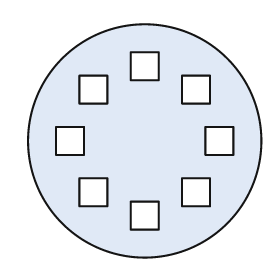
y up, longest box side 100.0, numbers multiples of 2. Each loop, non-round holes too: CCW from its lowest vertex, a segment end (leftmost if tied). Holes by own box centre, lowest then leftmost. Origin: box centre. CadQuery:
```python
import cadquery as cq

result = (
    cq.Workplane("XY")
    .moveTo(0.0, 0.0)
    .circle(50.0)
    .moveTo(-6.0, -38.0)
    .lineTo(6.0, -38.0)
    .lineTo(6.0, -26.0)
    .lineTo(-6.0, -26.0)
    .close()
    .moveTo(-28.0, -28.0)
    .lineTo(-16.0, -28.0)
    .lineTo(-16.0, -16.0)
    .lineTo(-28.0, -16.0)
    .close()
    .moveTo(16.0, -28.0)
    .lineTo(28.0, -28.0)
    .lineTo(28.0, -16.0)
    .lineTo(16.0, -16.0)
    .close()
    .moveTo(-38.0, -6.0)
    .lineTo(-26.0, -6.0)
    .lineTo(-26.0, 6.0)
    .lineTo(-38.0, 6.0)
    .close()
    .moveTo(26.0, -6.0)
    .lineTo(38.0, -6.0)
    .lineTo(38.0, 6.0)
    .lineTo(26.0, 6.0)
    .close()
    .moveTo(-28.0, 16.0)
    .lineTo(-16.0, 16.0)
    .lineTo(-16.0, 28.0)
    .lineTo(-28.0, 28.0)
    .close()
    .moveTo(16.0, 16.0)
    .lineTo(28.0, 16.0)
    .lineTo(28.0, 28.0)
    .lineTo(16.0, 28.0)
    .close()
    .moveTo(-6.0, 26.0)
    .lineTo(6.0, 26.0)
    .lineTo(6.0, 38.0)
    .lineTo(-6.0, 38.0)
    .close()
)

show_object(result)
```